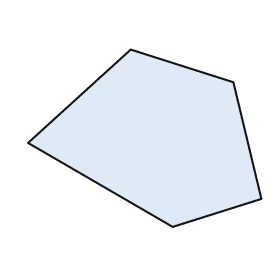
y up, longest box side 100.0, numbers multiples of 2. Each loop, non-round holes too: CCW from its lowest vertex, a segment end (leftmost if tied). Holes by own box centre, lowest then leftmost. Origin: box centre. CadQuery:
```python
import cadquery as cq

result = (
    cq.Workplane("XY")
    .moveTo(12.0, -38.0)
    .lineTo(50.0, -26.0)
    .lineTo(38.0, 24.0)
    .lineTo(-6.0, 38.0)
    .lineTo(-50.0, -2.0)
    .close()
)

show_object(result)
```